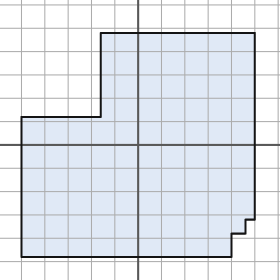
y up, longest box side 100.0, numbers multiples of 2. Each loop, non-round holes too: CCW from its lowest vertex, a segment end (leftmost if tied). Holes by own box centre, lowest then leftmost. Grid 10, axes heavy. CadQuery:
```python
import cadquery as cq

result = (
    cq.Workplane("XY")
    .moveTo(-50.0, -48.0)
    .lineTo(40.0, -48.0)
    .lineTo(40.0, -38.0)
    .lineTo(46.0, -38.0)
    .lineTo(46.0, -32.0)
    .lineTo(50.0, -32.0)
    .lineTo(50.0, 48.0)
    .lineTo(-16.0, 48.0)
    .lineTo(-16.0, 12.0)
    .lineTo(-50.0, 12.0)
    .close()
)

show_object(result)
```